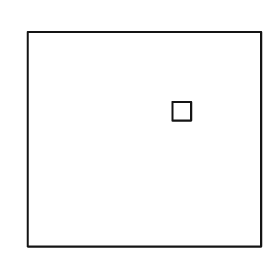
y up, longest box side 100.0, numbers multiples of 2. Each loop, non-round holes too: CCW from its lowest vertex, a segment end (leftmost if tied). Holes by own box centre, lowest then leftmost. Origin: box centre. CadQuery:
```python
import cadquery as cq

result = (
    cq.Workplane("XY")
    .moveTo(-50.0, -46.0)
    .lineTo(50.0, -46.0)
    .lineTo(50.0, 46.0)
    .lineTo(-50.0, 46.0)
    .close()
    .moveTo(12.0, 8.0)
    .lineTo(20.0, 8.0)
    .lineTo(20.0, 16.0)
    .lineTo(12.0, 16.0)
    .close()
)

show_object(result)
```